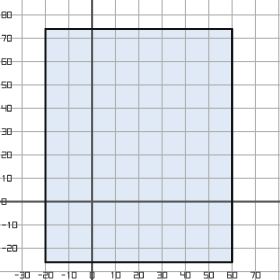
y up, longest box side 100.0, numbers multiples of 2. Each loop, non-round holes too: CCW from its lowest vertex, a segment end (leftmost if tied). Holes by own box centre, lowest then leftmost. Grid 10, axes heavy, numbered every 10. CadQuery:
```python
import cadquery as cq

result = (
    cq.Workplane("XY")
    .moveTo(-20.0, -26.0)
    .lineTo(60.0, -26.0)
    .lineTo(60.0, 74.0)
    .lineTo(-20.0, 74.0)
    .close()
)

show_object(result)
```